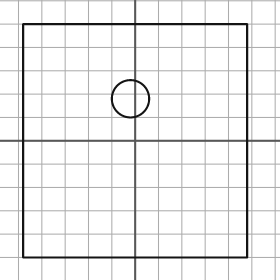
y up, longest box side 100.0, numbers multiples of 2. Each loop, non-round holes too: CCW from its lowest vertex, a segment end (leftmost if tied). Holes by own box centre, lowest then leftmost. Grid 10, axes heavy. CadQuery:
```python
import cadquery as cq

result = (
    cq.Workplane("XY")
    .moveTo(-48.0, -50.0)
    .lineTo(48.0, -50.0)
    .lineTo(48.0, 50.0)
    .lineTo(-48.0, 50.0)
    .close()
    .moveTo(-2.0, 18.0)
    .circle(8.0)
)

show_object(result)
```